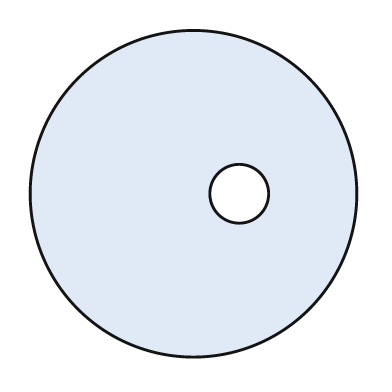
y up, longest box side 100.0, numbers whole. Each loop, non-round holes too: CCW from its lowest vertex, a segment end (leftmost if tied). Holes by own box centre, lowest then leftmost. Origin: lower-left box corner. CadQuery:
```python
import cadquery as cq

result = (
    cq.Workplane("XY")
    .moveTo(50.0, 50.0)
    .circle(50.0)
    .moveTo(64.0, 50.0)
    .circle(9.0)
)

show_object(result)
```